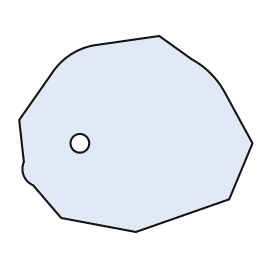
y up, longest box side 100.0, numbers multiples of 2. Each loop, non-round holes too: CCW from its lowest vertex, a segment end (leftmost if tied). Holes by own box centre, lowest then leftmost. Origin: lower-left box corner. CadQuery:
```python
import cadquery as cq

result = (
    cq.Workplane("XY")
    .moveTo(50.0, 0.0)
    .lineTo(90.0, 14.0)
    .lineTo(100.0, 38.0)
    .lineTo(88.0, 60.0)
    .threePointArc((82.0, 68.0), (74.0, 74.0))
    .lineTo(60.0, 84.0)
    .lineTo(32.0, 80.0)
    .threePointArc((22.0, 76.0), (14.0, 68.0))
    .lineTo(0.0, 48.0)
    .lineTo(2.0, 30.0)
    .threePointArc((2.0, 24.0), (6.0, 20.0))
    .lineTo(18.0, 6.0)
    .close()
    .moveTo(26.0, 38.0)
    .circle(4.0)
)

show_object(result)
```